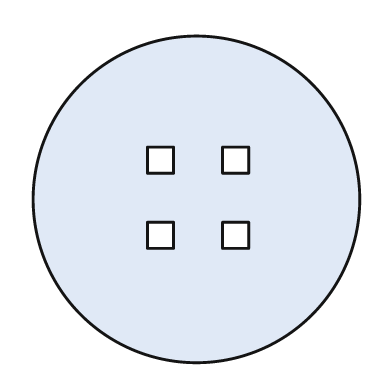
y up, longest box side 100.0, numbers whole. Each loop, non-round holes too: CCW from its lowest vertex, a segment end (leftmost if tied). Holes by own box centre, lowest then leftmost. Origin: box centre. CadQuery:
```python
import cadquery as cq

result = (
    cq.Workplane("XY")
    .moveTo(0.0, 0.0)
    .circle(50.0)
    .moveTo(-15.0, -15.0)
    .lineTo(-7.0, -15.0)
    .lineTo(-7.0, -7.0)
    .lineTo(-15.0, -7.0)
    .close()
    .moveTo(8.0, -15.0)
    .lineTo(16.0, -15.0)
    .lineTo(16.0, -7.0)
    .lineTo(8.0, -7.0)
    .close()
    .moveTo(-15.0, 8.0)
    .lineTo(-7.0, 8.0)
    .lineTo(-7.0, 16.0)
    .lineTo(-15.0, 16.0)
    .close()
    .moveTo(8.0, 8.0)
    .lineTo(16.0, 8.0)
    .lineTo(16.0, 16.0)
    .lineTo(8.0, 16.0)
    .close()
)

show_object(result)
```